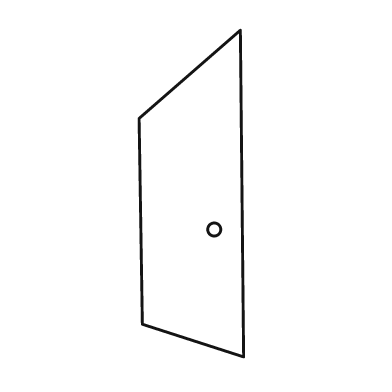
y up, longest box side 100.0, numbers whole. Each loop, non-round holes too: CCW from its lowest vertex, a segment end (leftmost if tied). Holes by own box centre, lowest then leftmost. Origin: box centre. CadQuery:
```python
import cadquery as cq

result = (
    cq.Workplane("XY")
    .moveTo(16.0, -50.0)
    .lineTo(15.0, 50.0)
    .lineTo(-16.0, 23.0)
    .lineTo(-15.0, -40.0)
    .close()
    .moveTo(7.0, -11.0)
    .circle(2.0)
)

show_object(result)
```